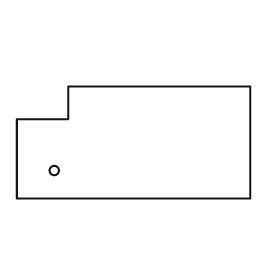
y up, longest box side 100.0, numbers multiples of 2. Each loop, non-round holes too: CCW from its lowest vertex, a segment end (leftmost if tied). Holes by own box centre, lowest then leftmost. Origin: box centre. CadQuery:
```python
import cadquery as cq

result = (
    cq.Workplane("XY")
    .moveTo(-50.0, -24.0)
    .lineTo(50.0, -24.0)
    .lineTo(50.0, 24.0)
    .lineTo(-28.0, 24.0)
    .lineTo(-28.0, 10.0)
    .lineTo(-50.0, 10.0)
    .close()
    .moveTo(-34.0, -12.0)
    .circle(2.0)
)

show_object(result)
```